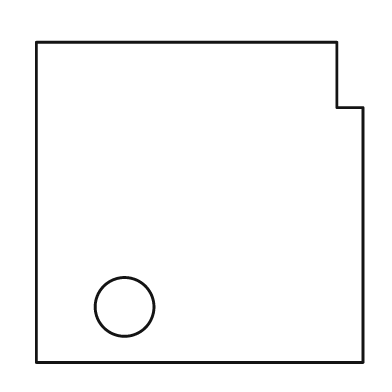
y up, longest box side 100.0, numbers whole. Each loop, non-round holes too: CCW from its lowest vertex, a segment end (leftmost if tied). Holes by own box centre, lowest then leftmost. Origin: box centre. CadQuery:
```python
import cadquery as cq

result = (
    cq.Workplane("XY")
    .moveTo(-50.0, -49.0)
    .lineTo(50.0, -49.0)
    .lineTo(50.0, 29.0)
    .lineTo(42.0, 29.0)
    .lineTo(42.0, 49.0)
    .lineTo(-50.0, 49.0)
    .close()
    .moveTo(-23.0, -32.0)
    .circle(9.0)
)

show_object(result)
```